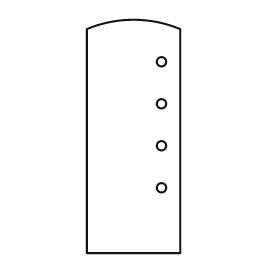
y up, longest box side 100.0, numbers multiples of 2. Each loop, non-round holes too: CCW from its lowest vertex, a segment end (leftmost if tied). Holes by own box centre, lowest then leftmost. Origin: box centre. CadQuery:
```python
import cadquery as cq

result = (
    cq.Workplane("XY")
    .moveTo(-20.0, -50.0)
    .lineTo(20.0, -50.0)
    .lineTo(20.0, 46.0)
    .threePointArc((0.0, 50.0), (-20.0, 46.0))
    .close()
    .moveTo(12.0, -22.0)
    .circle(2.0)
    .moveTo(12.0, -4.0)
    .circle(2.0)
    .moveTo(12.0, 14.0)
    .circle(2.0)
    .moveTo(12.0, 32.0)
    .circle(2.0)
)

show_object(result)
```